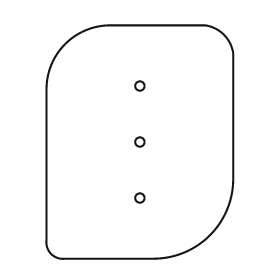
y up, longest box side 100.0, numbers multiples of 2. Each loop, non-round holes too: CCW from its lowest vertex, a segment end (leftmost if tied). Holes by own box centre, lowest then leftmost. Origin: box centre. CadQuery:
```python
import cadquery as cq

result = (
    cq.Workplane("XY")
    .moveTo(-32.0, -50.0)
    .lineTo(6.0, -50.0)
    .threePointArc((30.0, -40.0), (40.0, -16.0))
    .lineTo(40.0, 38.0)
    .threePointArc((36.0, 46.0), (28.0, 50.0))
    .lineTo(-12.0, 50.0)
    .threePointArc((-32.0, 42.0), (-40.0, 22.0))
    .lineTo(-40.0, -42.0)
    .threePointArc((-38.0, -48.0), (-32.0, -50.0))
    .close()
    .moveTo(0.0, -24.0)
    .circle(2.0)
    .moveTo(0.0, 0.0)
    .circle(2.0)
    .moveTo(0.0, 24.0)
    .circle(2.0)
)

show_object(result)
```